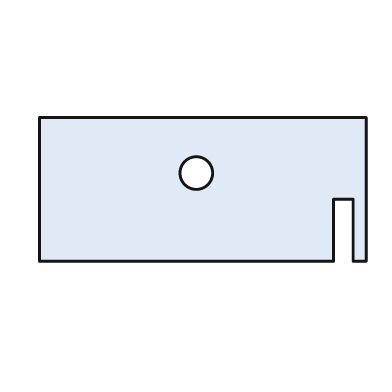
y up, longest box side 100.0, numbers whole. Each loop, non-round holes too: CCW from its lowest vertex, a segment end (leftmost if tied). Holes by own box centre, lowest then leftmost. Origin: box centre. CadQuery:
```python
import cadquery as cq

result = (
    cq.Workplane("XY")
    .moveTo(-50.0, -22.0)
    .lineTo(40.0, -22.0)
    .lineTo(40.0, -3.0)
    .lineTo(46.0, -3.0)
    .lineTo(46.0, -22.0)
    .lineTo(50.0, -22.0)
    .lineTo(50.0, 22.0)
    .lineTo(-50.0, 22.0)
    .close()
    .moveTo(-2.0, 5.0)
    .circle(5.0)
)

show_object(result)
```